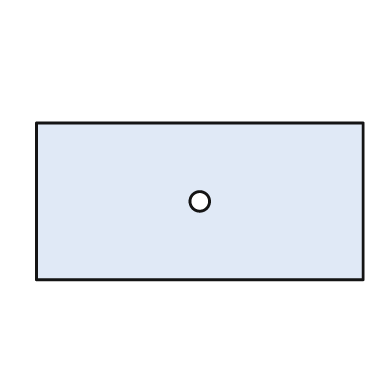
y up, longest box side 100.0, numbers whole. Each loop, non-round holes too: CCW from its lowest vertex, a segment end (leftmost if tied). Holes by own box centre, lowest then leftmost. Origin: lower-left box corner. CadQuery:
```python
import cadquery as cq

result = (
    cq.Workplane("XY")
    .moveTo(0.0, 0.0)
    .lineTo(100.0, 0.0)
    .lineTo(100.0, 48.0)
    .lineTo(0.0, 48.0)
    .close()
    .moveTo(50.0, 24.0)
    .circle(3.0)
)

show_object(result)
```